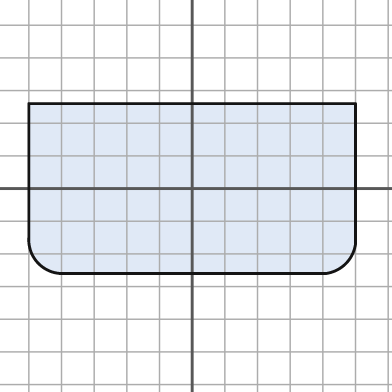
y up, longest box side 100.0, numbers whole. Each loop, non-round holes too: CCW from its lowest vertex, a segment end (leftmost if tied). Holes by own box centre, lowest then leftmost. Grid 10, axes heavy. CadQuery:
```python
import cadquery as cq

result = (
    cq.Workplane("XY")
    .moveTo(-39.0, -26.0)
    .lineTo(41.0, -26.0)
    .threePointArc((47.0, -23.0), (50.0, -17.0))
    .lineTo(50.0, 26.0)
    .lineTo(-50.0, 26.0)
    .lineTo(-50.0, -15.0)
    .threePointArc((-47.0, -23.0), (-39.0, -26.0))
    .close()
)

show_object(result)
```